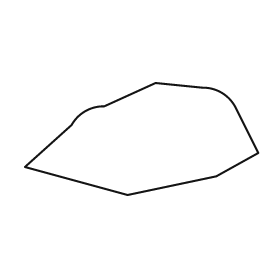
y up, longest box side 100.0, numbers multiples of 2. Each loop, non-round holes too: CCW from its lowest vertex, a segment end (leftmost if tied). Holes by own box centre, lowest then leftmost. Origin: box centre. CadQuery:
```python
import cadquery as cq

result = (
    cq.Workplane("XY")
    .moveTo(-6.0, -24.0)
    .lineTo(32.0, -16.0)
    .lineTo(50.0, -6.0)
    .lineTo(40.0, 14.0)
    .threePointArc((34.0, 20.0), (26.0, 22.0))
    .lineTo(6.0, 24.0)
    .lineTo(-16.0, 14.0)
    .threePointArc((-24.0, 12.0), (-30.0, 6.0))
    .lineTo(-50.0, -12.0)
    .close()
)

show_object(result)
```